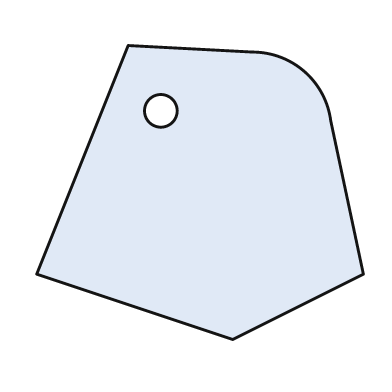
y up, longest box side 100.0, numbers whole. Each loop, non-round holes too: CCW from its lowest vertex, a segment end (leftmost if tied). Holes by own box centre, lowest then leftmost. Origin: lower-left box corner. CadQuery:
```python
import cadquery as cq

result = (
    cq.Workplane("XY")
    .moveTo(60.0, 0.0)
    .lineTo(100.0, 20.0)
    .lineTo(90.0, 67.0)
    .threePointArc((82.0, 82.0), (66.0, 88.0))
    .lineTo(28.0, 90.0)
    .lineTo(0.0, 20.0)
    .close()
    .moveTo(38.0, 70.0)
    .circle(5.0)
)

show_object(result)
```